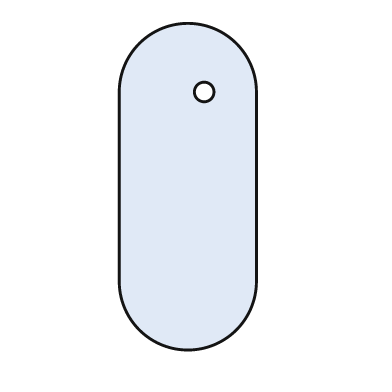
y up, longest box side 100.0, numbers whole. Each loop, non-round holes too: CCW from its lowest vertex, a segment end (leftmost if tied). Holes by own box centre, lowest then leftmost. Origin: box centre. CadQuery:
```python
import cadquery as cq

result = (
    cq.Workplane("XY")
    .moveTo(-21.0, -29.0)
    .threePointArc((0.0, -50.0), (21.0, -29.0))
    .lineTo(21.0, 29.0)
    .threePointArc((0.0, 50.0), (-21.0, 29.0))
    .close()
    .moveTo(5.0, 29.0)
    .circle(3.0)
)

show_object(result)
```